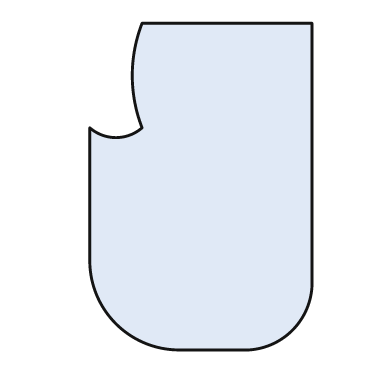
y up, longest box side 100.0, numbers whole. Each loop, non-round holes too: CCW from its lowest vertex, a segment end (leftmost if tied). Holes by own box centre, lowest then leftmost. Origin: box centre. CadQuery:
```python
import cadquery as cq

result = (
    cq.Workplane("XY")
    .moveTo(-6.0, -50.0)
    .lineTo(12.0, -50.0)
    .threePointArc((28.0, -44.0), (34.0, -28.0))
    .lineTo(34.0, 50.0)
    .lineTo(-18.0, 50.0)
    .threePointArc((-21.0, 34.0), (-18.0, 18.0))
    .threePointArc((-26.0, 15.0), (-34.0, 18.0))
    .lineTo(-34.0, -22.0)
    .threePointArc((-26.0, -42.0), (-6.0, -50.0))
    .close()
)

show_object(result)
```